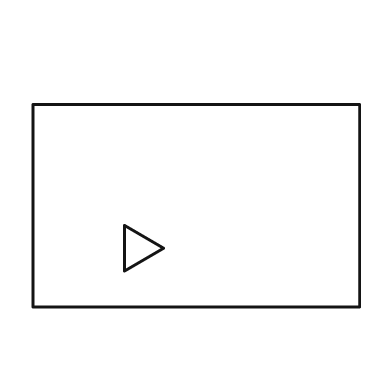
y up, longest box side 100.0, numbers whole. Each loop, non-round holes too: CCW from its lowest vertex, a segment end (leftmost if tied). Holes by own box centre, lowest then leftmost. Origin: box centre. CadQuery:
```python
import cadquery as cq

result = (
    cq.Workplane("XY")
    .moveTo(-50.0, -31.0)
    .lineTo(50.0, -31.0)
    .lineTo(50.0, 31.0)
    .lineTo(-50.0, 31.0)
    .close()
    .moveTo(-22.0, -20.0)
    .lineTo(-10.0, -13.0)
    .lineTo(-22.0, -6.0)
    .close()
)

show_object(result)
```